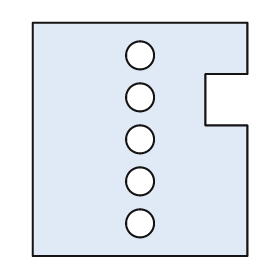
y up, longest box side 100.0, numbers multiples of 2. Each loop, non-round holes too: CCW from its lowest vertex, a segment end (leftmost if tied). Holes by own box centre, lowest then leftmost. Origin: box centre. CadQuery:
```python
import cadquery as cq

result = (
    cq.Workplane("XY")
    .moveTo(-46.0, -50.0)
    .lineTo(46.0, -50.0)
    .lineTo(46.0, 6.0)
    .lineTo(28.0, 6.0)
    .lineTo(28.0, 28.0)
    .lineTo(46.0, 28.0)
    .lineTo(46.0, 50.0)
    .lineTo(-46.0, 50.0)
    .close()
    .moveTo(0.0, -36.0)
    .circle(6.0)
    .moveTo(0.0, -18.0)
    .circle(6.0)
    .moveTo(0.0, 0.0)
    .circle(6.0)
    .moveTo(0.0, 18.0)
    .circle(6.0)
    .moveTo(0.0, 36.0)
    .circle(6.0)
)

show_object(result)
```